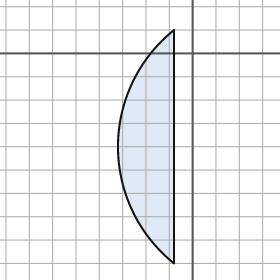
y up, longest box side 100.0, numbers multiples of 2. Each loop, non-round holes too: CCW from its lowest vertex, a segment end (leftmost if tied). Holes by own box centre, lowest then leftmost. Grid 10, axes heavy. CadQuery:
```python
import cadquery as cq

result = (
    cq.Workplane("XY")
    .moveTo(-8.0, -90.0)
    .lineTo(-8.0, 10.0)
    .threePointArc((-32.0, -40.0), (-8.0, -90.0))
    .close()
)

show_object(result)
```